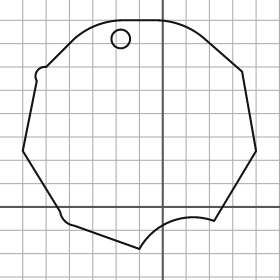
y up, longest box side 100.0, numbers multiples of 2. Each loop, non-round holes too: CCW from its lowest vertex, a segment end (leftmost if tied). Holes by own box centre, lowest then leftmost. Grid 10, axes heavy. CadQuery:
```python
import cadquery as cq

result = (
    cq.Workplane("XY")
    .moveTo(-10.0, -18.0)
    .threePointArc((4.0, -6.0), (22.0, -6.0))
    .lineTo(40.0, 24.0)
    .lineTo(34.0, 58.0)
    .lineTo(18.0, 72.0)
    .threePointArc((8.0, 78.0), (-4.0, 80.0))
    .lineTo(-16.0, 80.0)
    .threePointArc((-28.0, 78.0), (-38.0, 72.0))
    .lineTo(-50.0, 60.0)
    .threePointArc((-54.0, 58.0), (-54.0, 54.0))
    .lineTo(-60.0, 24.0)
    .lineTo(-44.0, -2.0)
    .threePointArc((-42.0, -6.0), (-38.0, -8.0))
    .close()
    .moveTo(-18.0, 72.0)
    .circle(4.0)
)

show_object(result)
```